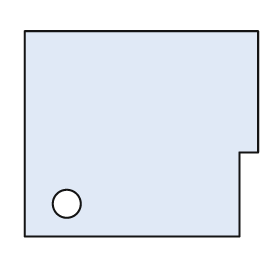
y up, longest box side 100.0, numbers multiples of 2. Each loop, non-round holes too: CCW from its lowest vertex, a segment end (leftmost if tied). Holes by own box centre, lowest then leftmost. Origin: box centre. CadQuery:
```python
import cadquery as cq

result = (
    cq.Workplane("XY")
    .moveTo(-50.0, -44.0)
    .lineTo(42.0, -44.0)
    .lineTo(42.0, -8.0)
    .lineTo(50.0, -8.0)
    .lineTo(50.0, 44.0)
    .lineTo(-50.0, 44.0)
    .close()
    .moveTo(-32.0, -30.0)
    .circle(6.0)
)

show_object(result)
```